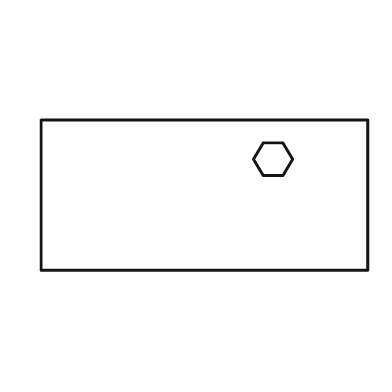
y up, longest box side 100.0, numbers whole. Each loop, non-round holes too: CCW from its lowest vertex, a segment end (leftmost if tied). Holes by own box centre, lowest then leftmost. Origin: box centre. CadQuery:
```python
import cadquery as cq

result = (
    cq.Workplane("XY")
    .moveTo(-50.0, -23.0)
    .lineTo(50.0, -23.0)
    .lineTo(50.0, 23.0)
    .lineTo(-50.0, 23.0)
    .close()
    .moveTo(18.0, 6.0)
    .lineTo(24.0, 6.0)
    .lineTo(27.0, 11.0)
    .lineTo(24.0, 16.0)
    .lineTo(18.0, 16.0)
    .lineTo(15.0, 11.0)
    .close()
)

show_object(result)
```